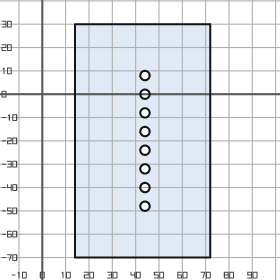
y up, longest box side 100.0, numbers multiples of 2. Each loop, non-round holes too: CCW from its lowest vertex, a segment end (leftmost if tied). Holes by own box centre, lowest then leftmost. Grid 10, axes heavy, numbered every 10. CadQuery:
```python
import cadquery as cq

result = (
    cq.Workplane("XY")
    .moveTo(14.0, -70.0)
    .lineTo(72.0, -70.0)
    .lineTo(72.0, 30.0)
    .lineTo(14.0, 30.0)
    .close()
    .moveTo(44.0, -48.0)
    .circle(2.0)
    .moveTo(44.0, -40.0)
    .circle(2.0)
    .moveTo(44.0, -32.0)
    .circle(2.0)
    .moveTo(44.0, -24.0)
    .circle(2.0)
    .moveTo(44.0, -16.0)
    .circle(2.0)
    .moveTo(44.0, -8.0)
    .circle(2.0)
    .moveTo(44.0, 0.0)
    .circle(2.0)
    .moveTo(44.0, 8.0)
    .circle(2.0)
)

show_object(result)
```